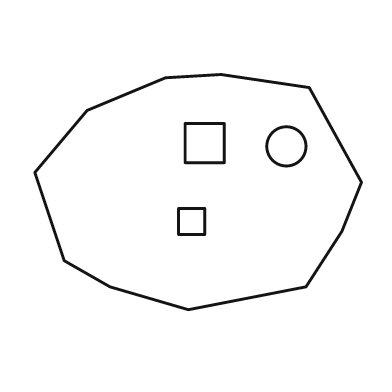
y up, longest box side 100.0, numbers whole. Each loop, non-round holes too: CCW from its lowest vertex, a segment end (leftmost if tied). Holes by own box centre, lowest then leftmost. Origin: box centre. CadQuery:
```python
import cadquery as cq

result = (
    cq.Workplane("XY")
    .moveTo(-3.0, -36.0)
    .lineTo(33.0, -29.0)
    .lineTo(44.0, -12.0)
    .lineTo(50.0, 3.0)
    .lineTo(34.0, 32.0)
    .lineTo(7.0, 36.0)
    .lineTo(-10.0, 35.0)
    .lineTo(-34.0, 25.0)
    .lineTo(-50.0, 6.0)
    .lineTo(-41.0, -21.0)
    .lineTo(-27.0, -29.0)
    .close()
    .moveTo(-6.0, -13.0)
    .lineTo(2.0, -13.0)
    .lineTo(2.0, -5.0)
    .lineTo(-6.0, -5.0)
    .close()
    .moveTo(27.0, 14.0)
    .circle(6.0)
    .moveTo(-4.0, 9.0)
    .lineTo(8.0, 9.0)
    .lineTo(8.0, 21.0)
    .lineTo(-4.0, 21.0)
    .close()
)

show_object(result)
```